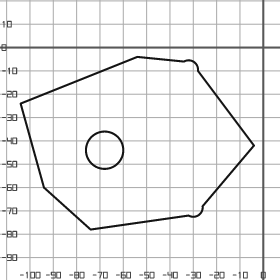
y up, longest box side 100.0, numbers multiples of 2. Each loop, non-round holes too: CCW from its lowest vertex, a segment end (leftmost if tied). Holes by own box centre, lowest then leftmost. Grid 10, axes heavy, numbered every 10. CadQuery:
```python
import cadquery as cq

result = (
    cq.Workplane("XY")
    .moveTo(-74.0, -78.0)
    .lineTo(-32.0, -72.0)
    .threePointArc((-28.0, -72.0), (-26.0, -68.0))
    .lineTo(-4.0, -42.0)
    .lineTo(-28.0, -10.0)
    .threePointArc((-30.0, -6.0), (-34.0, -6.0))
    .lineTo(-54.0, -4.0)
    .lineTo(-104.0, -24.0)
    .lineTo(-94.0, -60.0)
    .close()
    .moveTo(-68.0, -44.0)
    .circle(8.0)
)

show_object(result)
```